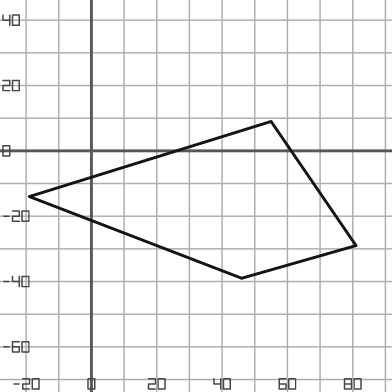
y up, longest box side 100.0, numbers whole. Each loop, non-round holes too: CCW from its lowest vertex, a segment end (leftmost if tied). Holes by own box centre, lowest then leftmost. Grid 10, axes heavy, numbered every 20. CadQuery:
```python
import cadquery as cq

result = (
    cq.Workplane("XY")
    .moveTo(46.0, -39.0)
    .lineTo(81.0, -29.0)
    .lineTo(55.0, 9.0)
    .lineTo(-19.0, -14.0)
    .close()
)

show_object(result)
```